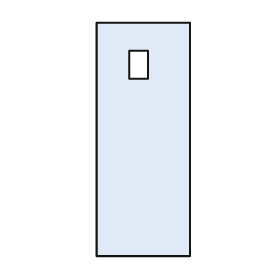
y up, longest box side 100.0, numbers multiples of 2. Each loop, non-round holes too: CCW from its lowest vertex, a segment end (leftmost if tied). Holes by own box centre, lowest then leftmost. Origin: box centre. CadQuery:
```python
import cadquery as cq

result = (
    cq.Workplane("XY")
    .moveTo(-20.0, -50.0)
    .lineTo(20.0, -50.0)
    .lineTo(20.0, 50.0)
    .lineTo(-20.0, 50.0)
    .close()
    .moveTo(-6.0, 26.0)
    .lineTo(2.0, 26.0)
    .lineTo(2.0, 38.0)
    .lineTo(-6.0, 38.0)
    .close()
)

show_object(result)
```